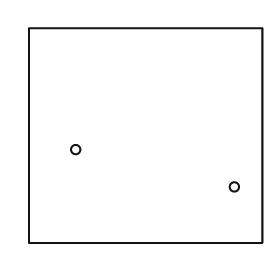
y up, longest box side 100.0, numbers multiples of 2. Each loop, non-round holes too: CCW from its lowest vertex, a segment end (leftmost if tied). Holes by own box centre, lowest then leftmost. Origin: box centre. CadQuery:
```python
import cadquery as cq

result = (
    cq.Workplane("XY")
    .moveTo(-50.0, -46.0)
    .lineTo(50.0, -46.0)
    .lineTo(50.0, 46.0)
    .lineTo(-50.0, 46.0)
    .close()
    .moveTo(38.0, -22.0)
    .circle(2.0)
    .moveTo(-30.0, -6.0)
    .circle(2.0)
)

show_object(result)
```